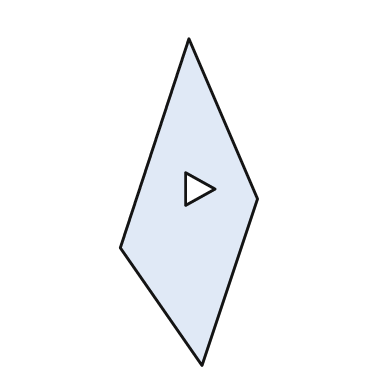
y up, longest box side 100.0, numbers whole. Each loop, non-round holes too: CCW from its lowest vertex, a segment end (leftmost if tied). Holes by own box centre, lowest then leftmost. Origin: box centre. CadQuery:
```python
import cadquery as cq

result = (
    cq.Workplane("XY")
    .moveTo(4.0, -50.0)
    .lineTo(21.0, 1.0)
    .lineTo(0.0, 50.0)
    .lineTo(-21.0, -14.0)
    .close()
    .moveTo(-1.0, -1.0)
    .lineTo(8.0, 4.0)
    .lineTo(-1.0, 9.0)
    .close()
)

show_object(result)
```